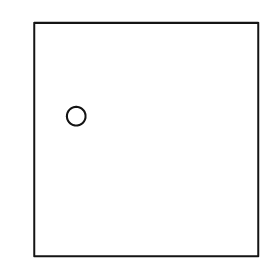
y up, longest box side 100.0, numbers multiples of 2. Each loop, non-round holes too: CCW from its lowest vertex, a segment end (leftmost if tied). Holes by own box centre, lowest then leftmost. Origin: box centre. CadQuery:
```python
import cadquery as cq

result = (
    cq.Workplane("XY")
    .moveTo(-48.0, -50.0)
    .lineTo(48.0, -50.0)
    .lineTo(48.0, 50.0)
    .lineTo(-48.0, 50.0)
    .close()
    .moveTo(-30.0, 10.0)
    .circle(4.0)
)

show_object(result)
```